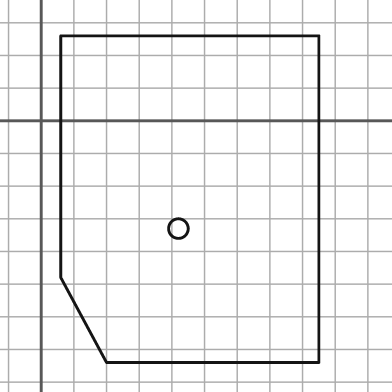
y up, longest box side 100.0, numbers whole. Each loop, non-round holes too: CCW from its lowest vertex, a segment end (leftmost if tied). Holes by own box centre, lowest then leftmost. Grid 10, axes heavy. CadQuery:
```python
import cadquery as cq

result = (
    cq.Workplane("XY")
    .moveTo(20.0, -74.0)
    .lineTo(85.0, -74.0)
    .lineTo(85.0, 26.0)
    .lineTo(6.0, 26.0)
    .lineTo(6.0, -48.0)
    .close()
    .moveTo(42.0, -33.0)
    .circle(3.0)
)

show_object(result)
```